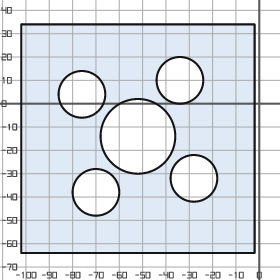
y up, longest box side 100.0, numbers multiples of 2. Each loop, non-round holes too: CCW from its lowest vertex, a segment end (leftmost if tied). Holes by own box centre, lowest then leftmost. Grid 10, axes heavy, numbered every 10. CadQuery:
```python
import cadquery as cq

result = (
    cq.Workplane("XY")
    .moveTo(-102.0, -64.0)
    .lineTo(-2.0, -64.0)
    .lineTo(-2.0, 34.0)
    .lineTo(-102.0, 34.0)
    .close()
    .moveTo(-70.0, -38.0)
    .circle(10.0)
    .moveTo(-28.0, -32.0)
    .circle(10.0)
    .moveTo(-52.0, -14.0)
    .circle(16.0)
    .moveTo(-76.0, 4.0)
    .circle(10.0)
    .moveTo(-34.0, 10.0)
    .circle(10.0)
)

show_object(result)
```